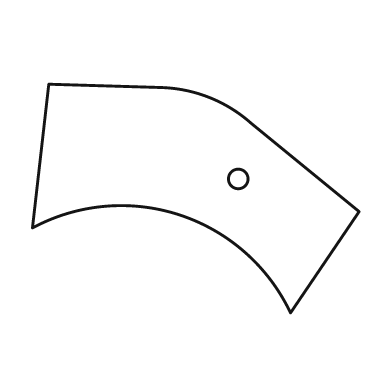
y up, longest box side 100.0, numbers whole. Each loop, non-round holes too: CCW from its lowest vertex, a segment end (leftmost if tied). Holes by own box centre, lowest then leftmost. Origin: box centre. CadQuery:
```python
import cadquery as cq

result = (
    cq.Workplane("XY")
    .moveTo(29.0, -35.0)
    .lineTo(50.0, -4.0)
    .lineTo(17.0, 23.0)
    .threePointArc((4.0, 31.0), (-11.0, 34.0))
    .lineTo(-45.0, 35.0)
    .lineTo(-50.0, -9.0)
    .threePointArc((-5.0, -5.0), (29.0, -35.0))
    .close()
    .moveTo(13.0, 6.0)
    .circle(3.0)
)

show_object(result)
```